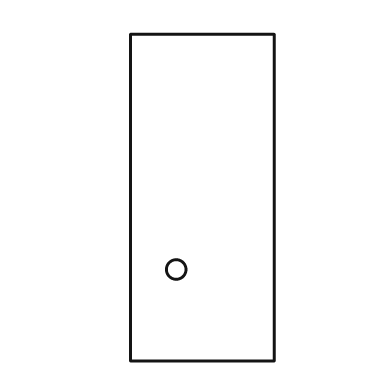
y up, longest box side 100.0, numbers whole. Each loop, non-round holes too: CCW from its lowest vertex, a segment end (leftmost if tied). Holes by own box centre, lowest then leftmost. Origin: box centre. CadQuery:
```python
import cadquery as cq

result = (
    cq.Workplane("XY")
    .moveTo(-22.0, -50.0)
    .lineTo(22.0, -50.0)
    .lineTo(22.0, 50.0)
    .lineTo(-22.0, 50.0)
    .close()
    .moveTo(-8.0, -22.0)
    .circle(3.0)
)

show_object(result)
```